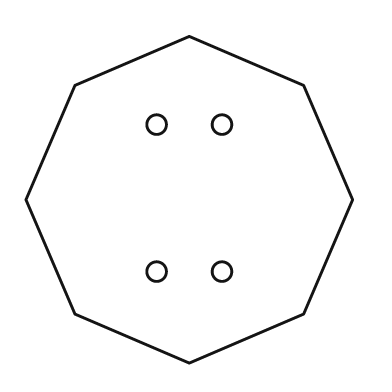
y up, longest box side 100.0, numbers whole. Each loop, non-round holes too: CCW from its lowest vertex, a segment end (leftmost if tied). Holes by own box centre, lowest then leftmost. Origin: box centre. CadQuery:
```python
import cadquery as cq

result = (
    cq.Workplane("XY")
    .moveTo(0.0, -50.0)
    .lineTo(35.0, -35.0)
    .lineTo(50.0, 0.0)
    .lineTo(35.0, 35.0)
    .lineTo(0.0, 50.0)
    .lineTo(-35.0, 35.0)
    .lineTo(-50.0, 0.0)
    .lineTo(-35.0, -35.0)
    .close()
    .moveTo(-10.0, -22.0)
    .circle(3.0)
    .moveTo(10.0, -22.0)
    .circle(3.0)
    .moveTo(-10.0, 23.0)
    .circle(3.0)
    .moveTo(10.0, 23.0)
    .circle(3.0)
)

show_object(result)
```